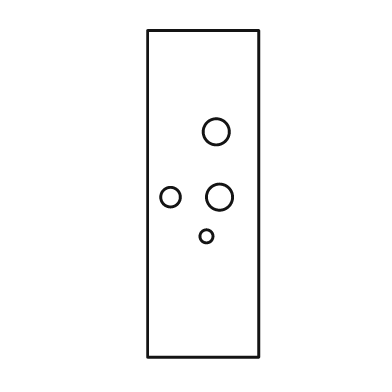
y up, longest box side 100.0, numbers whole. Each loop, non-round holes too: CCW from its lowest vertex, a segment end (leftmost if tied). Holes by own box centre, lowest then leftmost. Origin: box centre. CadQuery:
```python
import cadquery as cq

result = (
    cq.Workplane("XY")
    .moveTo(-17.0, -50.0)
    .lineTo(17.0, -50.0)
    .lineTo(17.0, 50.0)
    .lineTo(-17.0, 50.0)
    .close()
    .moveTo(1.0, -13.0)
    .circle(2.0)
    .moveTo(-10.0, -1.0)
    .circle(3.0)
    .moveTo(5.0, -1.0)
    .circle(4.0)
    .moveTo(4.0, 19.0)
    .circle(4.0)
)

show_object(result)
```